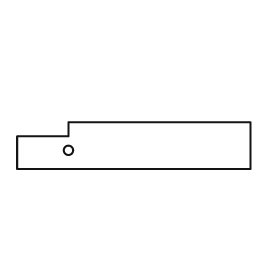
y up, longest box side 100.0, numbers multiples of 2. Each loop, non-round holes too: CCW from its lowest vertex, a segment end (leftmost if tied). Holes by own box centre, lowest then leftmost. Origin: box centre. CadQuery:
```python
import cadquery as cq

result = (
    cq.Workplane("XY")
    .moveTo(-50.0, -10.0)
    .lineTo(50.0, -10.0)
    .lineTo(50.0, 10.0)
    .lineTo(-28.0, 10.0)
    .lineTo(-28.0, 4.0)
    .lineTo(-50.0, 4.0)
    .close()
    .moveTo(-28.0, -2.0)
    .circle(2.0)
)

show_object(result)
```